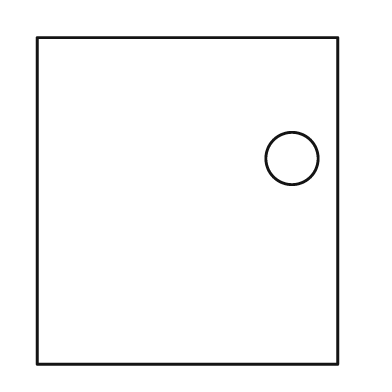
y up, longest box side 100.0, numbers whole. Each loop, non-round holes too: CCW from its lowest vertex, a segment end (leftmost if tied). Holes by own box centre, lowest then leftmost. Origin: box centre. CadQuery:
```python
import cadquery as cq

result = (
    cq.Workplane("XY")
    .moveTo(-46.0, -50.0)
    .lineTo(46.0, -50.0)
    .lineTo(46.0, 50.0)
    .lineTo(-46.0, 50.0)
    .close()
    .moveTo(32.0, 13.0)
    .circle(8.0)
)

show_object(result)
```